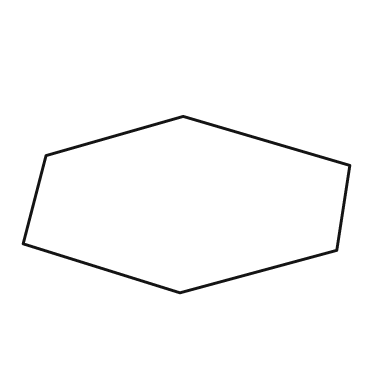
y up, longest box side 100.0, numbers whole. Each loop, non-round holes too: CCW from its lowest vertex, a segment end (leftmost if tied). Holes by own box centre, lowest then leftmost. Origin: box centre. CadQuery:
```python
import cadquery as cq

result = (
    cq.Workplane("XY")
    .moveTo(-2.0, -27.0)
    .lineTo(46.0, -14.0)
    .lineTo(50.0, 12.0)
    .lineTo(-1.0, 27.0)
    .lineTo(-43.0, 15.0)
    .lineTo(-50.0, -12.0)
    .close()
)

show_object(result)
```